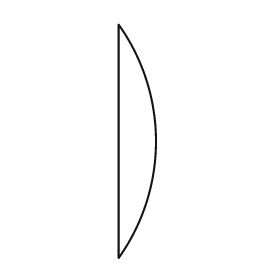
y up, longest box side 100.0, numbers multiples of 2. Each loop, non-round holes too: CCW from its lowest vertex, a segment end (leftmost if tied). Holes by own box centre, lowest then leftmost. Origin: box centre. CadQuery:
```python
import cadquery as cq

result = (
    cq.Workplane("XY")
    .moveTo(-8.0, -50.0)
    .threePointArc((8.0, 0.0), (-8.0, 50.0))
    .close()
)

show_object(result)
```